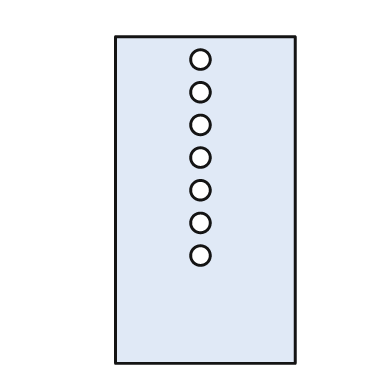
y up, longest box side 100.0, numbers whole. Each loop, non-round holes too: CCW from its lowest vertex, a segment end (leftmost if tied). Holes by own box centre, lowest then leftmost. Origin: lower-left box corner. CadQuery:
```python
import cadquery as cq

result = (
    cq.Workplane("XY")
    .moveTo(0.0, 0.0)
    .lineTo(55.0, 0.0)
    .lineTo(55.0, 100.0)
    .lineTo(0.0, 100.0)
    .close()
    .moveTo(26.0, 33.0)
    .circle(3.0)
    .moveTo(26.0, 43.0)
    .circle(3.0)
    .moveTo(26.0, 53.0)
    .circle(3.0)
    .moveTo(26.0, 63.0)
    .circle(3.0)
    .moveTo(26.0, 73.0)
    .circle(3.0)
    .moveTo(26.0, 83.0)
    .circle(3.0)
    .moveTo(26.0, 93.0)
    .circle(3.0)
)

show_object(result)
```